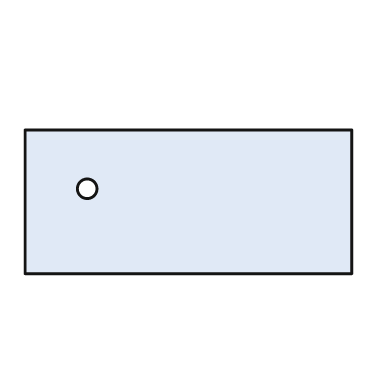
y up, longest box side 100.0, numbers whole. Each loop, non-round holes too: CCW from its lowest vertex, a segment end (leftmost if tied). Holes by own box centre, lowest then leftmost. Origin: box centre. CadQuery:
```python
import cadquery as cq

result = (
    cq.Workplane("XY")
    .moveTo(-50.0, -22.0)
    .lineTo(50.0, -22.0)
    .lineTo(50.0, 22.0)
    .lineTo(-50.0, 22.0)
    .close()
    .moveTo(-31.0, 4.0)
    .circle(3.0)
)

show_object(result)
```